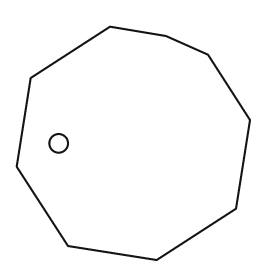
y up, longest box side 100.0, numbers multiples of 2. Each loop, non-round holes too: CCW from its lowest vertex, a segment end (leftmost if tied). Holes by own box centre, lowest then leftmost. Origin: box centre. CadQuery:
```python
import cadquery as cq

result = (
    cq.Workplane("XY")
    .moveTo(10.0, -50.0)
    .lineTo(44.0, -28.0)
    .lineTo(50.0, 10.0)
    .lineTo(32.0, 38.0)
    .lineTo(14.0, 46.0)
    .lineTo(-10.0, 50.0)
    .lineTo(-44.0, 28.0)
    .lineTo(-50.0, -10.0)
    .lineTo(-28.0, -44.0)
    .close()
    .moveTo(-32.0, 0.0)
    .circle(4.0)
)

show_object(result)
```